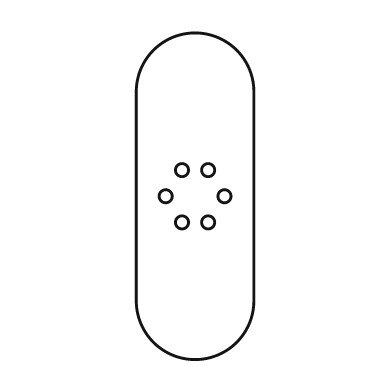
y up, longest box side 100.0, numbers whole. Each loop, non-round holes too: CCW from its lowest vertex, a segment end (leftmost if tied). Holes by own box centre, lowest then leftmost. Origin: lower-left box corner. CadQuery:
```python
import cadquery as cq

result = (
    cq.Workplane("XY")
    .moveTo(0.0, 18.0)
    .threePointArc((18.0, 0.0), (36.0, 18.0))
    .lineTo(36.0, 82.0)
    .threePointArc((18.0, 100.0), (0.0, 82.0))
    .close()
    .moveTo(14.0, 42.0)
    .circle(2.0)
    .moveTo(22.0, 42.0)
    .circle(2.0)
    .moveTo(9.0, 50.0)
    .circle(2.0)
    .moveTo(27.0, 50.0)
    .circle(2.0)
    .moveTo(14.0, 58.0)
    .circle(2.0)
    .moveTo(22.0, 58.0)
    .circle(2.0)
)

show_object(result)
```